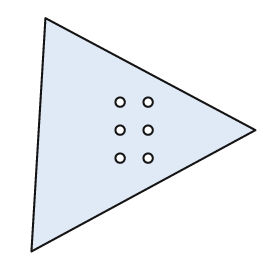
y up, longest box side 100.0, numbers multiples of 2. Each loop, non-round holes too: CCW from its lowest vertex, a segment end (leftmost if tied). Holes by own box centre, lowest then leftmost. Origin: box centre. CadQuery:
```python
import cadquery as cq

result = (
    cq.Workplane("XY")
    .moveTo(-48.0, -50.0)
    .lineTo(48.0, 2.0)
    .lineTo(-42.0, 50.0)
    .close()
    .moveTo(-10.0, -10.0)
    .circle(2.0)
    .moveTo(2.0, -10.0)
    .circle(2.0)
    .moveTo(-10.0, 2.0)
    .circle(2.0)
    .moveTo(2.0, 2.0)
    .circle(2.0)
    .moveTo(-10.0, 14.0)
    .circle(2.0)
    .moveTo(2.0, 14.0)
    .circle(2.0)
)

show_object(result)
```